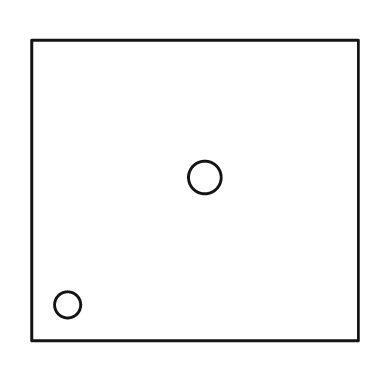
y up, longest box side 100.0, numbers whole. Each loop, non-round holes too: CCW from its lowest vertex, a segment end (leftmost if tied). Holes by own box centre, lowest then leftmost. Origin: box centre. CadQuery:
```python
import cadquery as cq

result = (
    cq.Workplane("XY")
    .moveTo(-50.0, -46.0)
    .lineTo(50.0, -46.0)
    .lineTo(50.0, 46.0)
    .lineTo(-50.0, 46.0)
    .close()
    .moveTo(-39.0, -35.0)
    .circle(4.0)
    .moveTo(3.0, 4.0)
    .circle(5.0)
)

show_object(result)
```